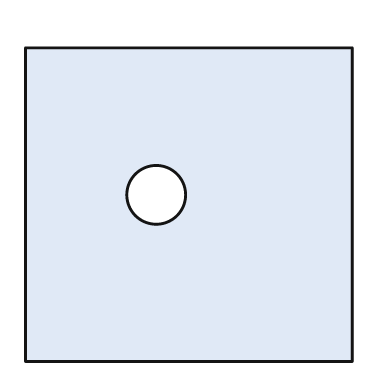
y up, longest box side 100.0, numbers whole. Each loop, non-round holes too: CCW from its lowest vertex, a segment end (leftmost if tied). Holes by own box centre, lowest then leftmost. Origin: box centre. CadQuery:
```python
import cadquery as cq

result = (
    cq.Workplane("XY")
    .moveTo(-50.0, -48.0)
    .lineTo(50.0, -48.0)
    .lineTo(50.0, 48.0)
    .lineTo(-50.0, 48.0)
    .close()
    .moveTo(-10.0, 3.0)
    .circle(9.0)
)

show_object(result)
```